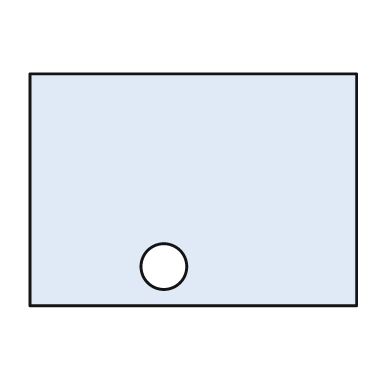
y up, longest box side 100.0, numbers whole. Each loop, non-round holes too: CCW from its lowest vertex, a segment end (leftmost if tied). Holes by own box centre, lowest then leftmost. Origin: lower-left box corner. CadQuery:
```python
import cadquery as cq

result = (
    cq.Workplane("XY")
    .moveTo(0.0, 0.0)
    .lineTo(100.0, 0.0)
    .lineTo(100.0, 71.0)
    .lineTo(0.0, 71.0)
    .close()
    .moveTo(41.0, 12.0)
    .circle(7.0)
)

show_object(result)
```